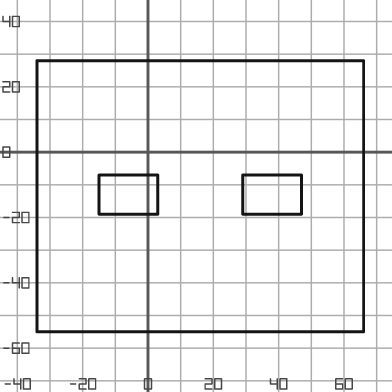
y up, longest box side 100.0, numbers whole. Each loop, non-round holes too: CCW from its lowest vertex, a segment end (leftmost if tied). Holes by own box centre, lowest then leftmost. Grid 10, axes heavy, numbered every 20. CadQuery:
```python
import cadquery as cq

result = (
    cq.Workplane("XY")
    .moveTo(-34.0, -55.0)
    .lineTo(66.0, -55.0)
    .lineTo(66.0, 28.0)
    .lineTo(-34.0, 28.0)
    .close()
    .moveTo(-15.0, -19.0)
    .lineTo(3.0, -19.0)
    .lineTo(3.0, -7.0)
    .lineTo(-15.0, -7.0)
    .close()
    .moveTo(29.0, -19.0)
    .lineTo(47.0, -19.0)
    .lineTo(47.0, -7.0)
    .lineTo(29.0, -7.0)
    .close()
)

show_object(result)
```